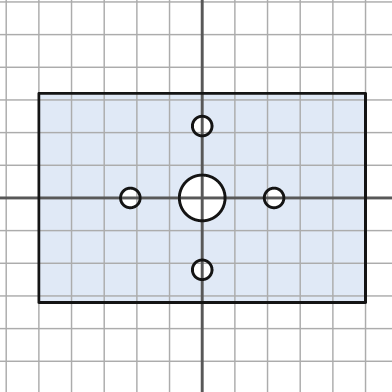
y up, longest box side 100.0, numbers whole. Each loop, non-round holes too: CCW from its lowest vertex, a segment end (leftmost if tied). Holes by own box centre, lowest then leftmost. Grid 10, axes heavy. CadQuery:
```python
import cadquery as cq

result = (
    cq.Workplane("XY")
    .moveTo(-50.0, -32.0)
    .lineTo(50.0, -32.0)
    .lineTo(50.0, 32.0)
    .lineTo(-50.0, 32.0)
    .close()
    .moveTo(0.0, -22.0)
    .circle(3.0)
    .moveTo(-22.0, 0.0)
    .circle(3.0)
    .moveTo(0.0, 0.0)
    .circle(7.0)
    .moveTo(22.0, 0.0)
    .circle(3.0)
    .moveTo(0.0, 22.0)
    .circle(3.0)
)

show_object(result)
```